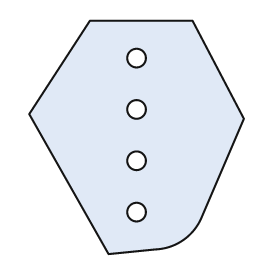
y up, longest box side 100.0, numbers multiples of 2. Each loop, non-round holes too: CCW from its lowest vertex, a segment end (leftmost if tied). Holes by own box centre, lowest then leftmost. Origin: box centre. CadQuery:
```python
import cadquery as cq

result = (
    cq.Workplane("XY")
    .moveTo(-12.0, -50.0)
    .lineTo(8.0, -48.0)
    .threePointArc((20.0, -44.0), (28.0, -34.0))
    .lineTo(46.0, 8.0)
    .lineTo(24.0, 50.0)
    .lineTo(-20.0, 50.0)
    .lineTo(-46.0, 10.0)
    .close()
    .moveTo(0.0, -32.0)
    .circle(4.0)
    .moveTo(0.0, -10.0)
    .circle(4.0)
    .moveTo(0.0, 12.0)
    .circle(4.0)
    .moveTo(0.0, 34.0)
    .circle(4.0)
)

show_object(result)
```